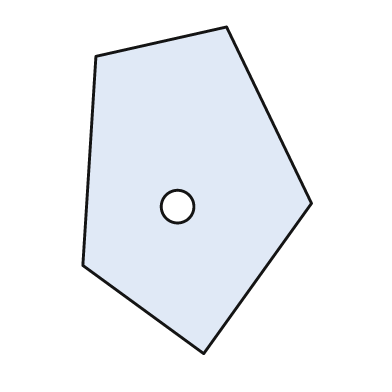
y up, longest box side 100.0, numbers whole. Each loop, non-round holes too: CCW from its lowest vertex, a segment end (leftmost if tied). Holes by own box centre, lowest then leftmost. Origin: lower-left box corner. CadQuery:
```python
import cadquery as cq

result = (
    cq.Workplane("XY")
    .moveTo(37.0, 0.0)
    .lineTo(70.0, 46.0)
    .lineTo(44.0, 100.0)
    .lineTo(4.0, 91.0)
    .lineTo(0.0, 27.0)
    .close()
    .moveTo(29.0, 45.0)
    .circle(5.0)
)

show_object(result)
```